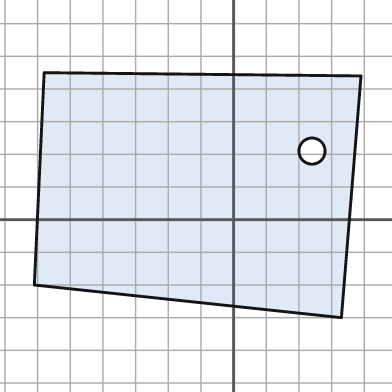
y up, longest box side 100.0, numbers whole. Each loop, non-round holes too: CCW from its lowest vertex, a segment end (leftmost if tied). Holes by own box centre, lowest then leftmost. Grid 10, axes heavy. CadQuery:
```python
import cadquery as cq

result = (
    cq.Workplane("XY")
    .moveTo(33.0, -30.0)
    .lineTo(39.0, 44.0)
    .lineTo(-58.0, 45.0)
    .lineTo(-61.0, -20.0)
    .close()
    .moveTo(24.0, 21.0)
    .circle(4.0)
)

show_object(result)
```